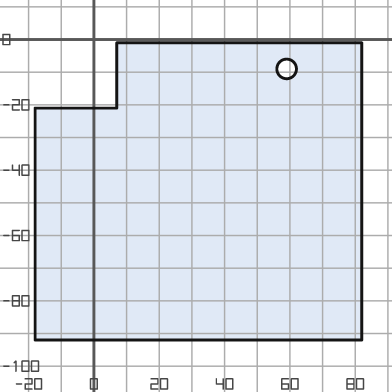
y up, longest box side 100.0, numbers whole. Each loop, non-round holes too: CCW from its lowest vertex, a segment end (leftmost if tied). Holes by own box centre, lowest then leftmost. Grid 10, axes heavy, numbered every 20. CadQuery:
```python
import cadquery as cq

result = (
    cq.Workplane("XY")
    .moveTo(-18.0, -92.0)
    .lineTo(82.0, -92.0)
    .lineTo(82.0, -1.0)
    .lineTo(7.0, -1.0)
    .lineTo(7.0, -21.0)
    .lineTo(-18.0, -21.0)
    .close()
    .moveTo(59.0, -9.0)
    .circle(3.0)
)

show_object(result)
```